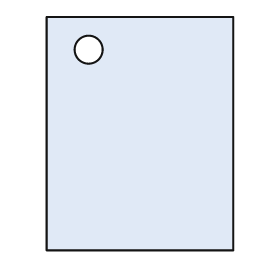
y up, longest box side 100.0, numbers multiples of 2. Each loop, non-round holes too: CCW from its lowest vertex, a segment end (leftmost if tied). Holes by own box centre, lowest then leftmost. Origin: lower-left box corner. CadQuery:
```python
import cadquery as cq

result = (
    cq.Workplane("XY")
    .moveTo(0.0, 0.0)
    .lineTo(80.0, 0.0)
    .lineTo(80.0, 100.0)
    .lineTo(0.0, 100.0)
    .close()
    .moveTo(18.0, 86.0)
    .circle(6.0)
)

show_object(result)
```